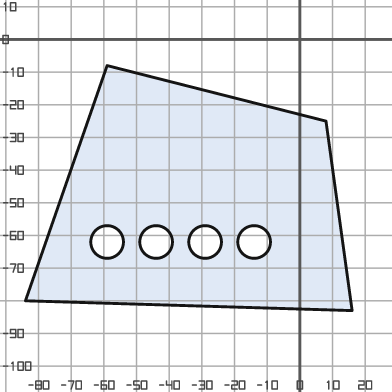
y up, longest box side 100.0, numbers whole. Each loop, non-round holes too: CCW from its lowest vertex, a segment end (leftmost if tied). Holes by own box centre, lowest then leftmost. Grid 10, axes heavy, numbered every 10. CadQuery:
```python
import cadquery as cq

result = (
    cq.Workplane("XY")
    .moveTo(16.0, -83.0)
    .lineTo(8.0, -25.0)
    .lineTo(-59.0, -8.0)
    .lineTo(-84.0, -80.0)
    .close()
    .moveTo(-59.0, -62.0)
    .circle(5.0)
    .moveTo(-44.0, -62.0)
    .circle(5.0)
    .moveTo(-29.0, -62.0)
    .circle(5.0)
    .moveTo(-14.0, -62.0)
    .circle(5.0)
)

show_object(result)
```